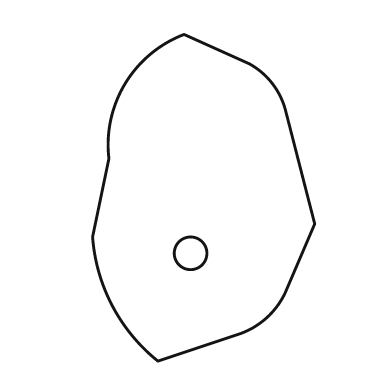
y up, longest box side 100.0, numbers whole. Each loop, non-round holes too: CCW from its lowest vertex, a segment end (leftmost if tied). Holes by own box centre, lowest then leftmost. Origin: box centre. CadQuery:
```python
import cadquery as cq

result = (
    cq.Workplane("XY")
    .moveTo(-14.0, -50.0)
    .lineTo(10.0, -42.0)
    .threePointArc((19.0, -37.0), (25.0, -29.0))
    .lineTo(34.0, -8.0)
    .lineTo(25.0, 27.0)
    .threePointArc((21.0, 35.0), (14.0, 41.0))
    .lineTo(-6.0, 50.0)
    .threePointArc((-24.0, 35.0), (-29.0, 12.0))
    .lineTo(-34.0, -12.0)
    .threePointArc((-28.0, -33.0), (-14.0, -50.0))
    .close()
    .moveTo(-4.0, -17.0)
    .circle(5.0)
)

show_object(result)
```